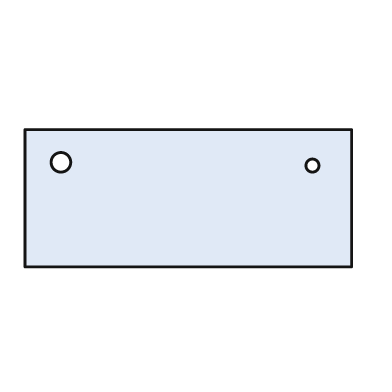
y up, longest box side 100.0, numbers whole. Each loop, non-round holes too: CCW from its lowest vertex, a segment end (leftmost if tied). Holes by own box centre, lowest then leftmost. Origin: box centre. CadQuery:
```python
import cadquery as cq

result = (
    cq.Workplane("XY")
    .moveTo(-50.0, -21.0)
    .lineTo(50.0, -21.0)
    .lineTo(50.0, 21.0)
    .lineTo(-50.0, 21.0)
    .close()
    .moveTo(38.0, 10.0)
    .circle(2.0)
    .moveTo(-39.0, 11.0)
    .circle(3.0)
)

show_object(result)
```